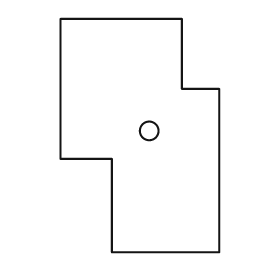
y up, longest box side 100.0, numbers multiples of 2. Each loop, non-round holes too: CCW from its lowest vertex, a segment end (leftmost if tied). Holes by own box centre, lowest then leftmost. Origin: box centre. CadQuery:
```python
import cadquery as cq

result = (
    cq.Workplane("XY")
    .moveTo(-12.0, -50.0)
    .lineTo(34.0, -50.0)
    .lineTo(34.0, 20.0)
    .lineTo(18.0, 20.0)
    .lineTo(18.0, 50.0)
    .lineTo(-34.0, 50.0)
    .lineTo(-34.0, -10.0)
    .lineTo(-12.0, -10.0)
    .close()
    .moveTo(4.0, 2.0)
    .circle(4.0)
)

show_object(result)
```